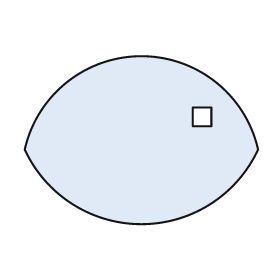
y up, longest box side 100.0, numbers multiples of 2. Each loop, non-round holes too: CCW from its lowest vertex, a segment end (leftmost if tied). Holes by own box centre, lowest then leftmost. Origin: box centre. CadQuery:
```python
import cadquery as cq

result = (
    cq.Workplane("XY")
    .moveTo(-50.0, -4.0)
    .threePointArc((0.0, -36.0), (50.0, -4.0))
    .threePointArc((0.0, 36.0), (-50.0, -4.0))
    .close()
    .moveTo(22.0, 6.0)
    .lineTo(30.0, 6.0)
    .lineTo(30.0, 14.0)
    .lineTo(22.0, 14.0)
    .close()
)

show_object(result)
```